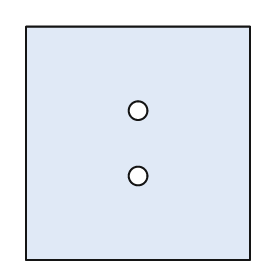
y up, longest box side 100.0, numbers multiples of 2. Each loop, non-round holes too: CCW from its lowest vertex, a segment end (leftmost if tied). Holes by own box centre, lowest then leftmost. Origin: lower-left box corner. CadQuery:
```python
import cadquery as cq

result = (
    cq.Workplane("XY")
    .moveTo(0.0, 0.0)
    .lineTo(96.0, 0.0)
    .lineTo(96.0, 100.0)
    .lineTo(0.0, 100.0)
    .close()
    .moveTo(48.0, 36.0)
    .circle(4.0)
    .moveTo(48.0, 64.0)
    .circle(4.0)
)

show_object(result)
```